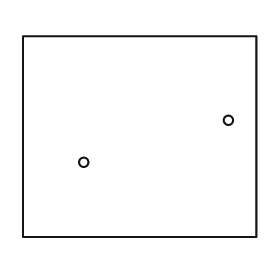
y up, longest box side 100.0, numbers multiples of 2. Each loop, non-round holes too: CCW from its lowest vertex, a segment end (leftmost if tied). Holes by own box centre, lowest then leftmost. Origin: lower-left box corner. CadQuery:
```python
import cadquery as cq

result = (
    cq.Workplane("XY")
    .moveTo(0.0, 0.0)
    .lineTo(100.0, 0.0)
    .lineTo(100.0, 86.0)
    .lineTo(0.0, 86.0)
    .close()
    .moveTo(26.0, 32.0)
    .circle(2.0)
    .moveTo(88.0, 50.0)
    .circle(2.0)
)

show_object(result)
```